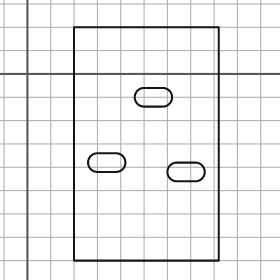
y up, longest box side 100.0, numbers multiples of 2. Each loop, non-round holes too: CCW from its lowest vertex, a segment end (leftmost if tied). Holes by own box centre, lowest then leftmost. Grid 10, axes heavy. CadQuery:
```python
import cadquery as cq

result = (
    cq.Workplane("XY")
    .moveTo(20.0, -80.0)
    .lineTo(82.0, -80.0)
    .lineTo(82.0, 20.0)
    .lineTo(20.0, 20.0)
    .close()
    .moveTo(64.0, -46.0)
    .lineTo(72.0, -46.0)
    .threePointArc((76.0, -42.0), (72.0, -38.0))
    .lineTo(64.0, -38.0)
    .threePointArc((60.0, -42.0), (64.0, -46.0))
    .close()
    .moveTo(30.0, -42.0)
    .lineTo(38.0, -42.0)
    .threePointArc((42.0, -38.0), (38.0, -34.0))
    .lineTo(30.0, -34.0)
    .threePointArc((26.0, -38.0), (30.0, -42.0))
    .close()
    .moveTo(50.0, -14.0)
    .lineTo(58.0, -14.0)
    .threePointArc((62.0, -10.0), (58.0, -6.0))
    .lineTo(50.0, -6.0)
    .threePointArc((46.0, -10.0), (50.0, -14.0))
    .close()
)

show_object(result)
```